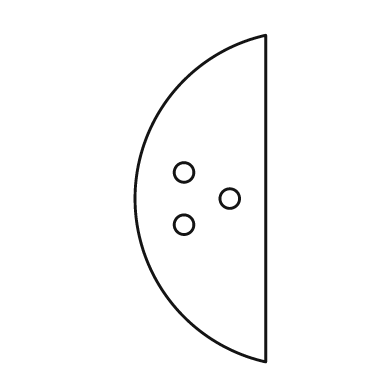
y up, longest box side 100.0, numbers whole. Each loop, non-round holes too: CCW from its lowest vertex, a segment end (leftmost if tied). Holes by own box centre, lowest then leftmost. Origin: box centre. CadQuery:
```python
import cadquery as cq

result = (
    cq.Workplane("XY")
    .moveTo(20.0, -50.0)
    .lineTo(20.0, 50.0)
    .threePointArc((-20.0, 0.0), (20.0, -50.0))
    .close()
    .moveTo(-5.0, -8.0)
    .circle(3.0)
    .moveTo(9.0, 0.0)
    .circle(3.0)
    .moveTo(-5.0, 8.0)
    .circle(3.0)
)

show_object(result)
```